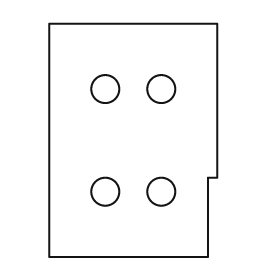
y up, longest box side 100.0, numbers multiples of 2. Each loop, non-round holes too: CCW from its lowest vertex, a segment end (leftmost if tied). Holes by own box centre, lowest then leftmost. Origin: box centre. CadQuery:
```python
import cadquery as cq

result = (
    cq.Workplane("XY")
    .moveTo(-36.0, -50.0)
    .lineTo(32.0, -50.0)
    .lineTo(32.0, -16.0)
    .lineTo(36.0, -16.0)
    .lineTo(36.0, 50.0)
    .lineTo(-36.0, 50.0)
    .close()
    .moveTo(-12.0, -22.0)
    .circle(6.0)
    .moveTo(12.0, -22.0)
    .circle(6.0)
    .moveTo(-12.0, 22.0)
    .circle(6.0)
    .moveTo(12.0, 22.0)
    .circle(6.0)
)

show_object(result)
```